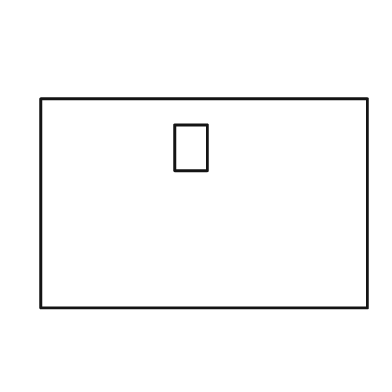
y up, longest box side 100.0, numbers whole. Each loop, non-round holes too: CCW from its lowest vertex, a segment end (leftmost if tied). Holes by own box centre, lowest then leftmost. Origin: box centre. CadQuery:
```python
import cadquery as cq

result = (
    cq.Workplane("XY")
    .moveTo(-50.0, -32.0)
    .lineTo(50.0, -32.0)
    .lineTo(50.0, 32.0)
    .lineTo(-50.0, 32.0)
    .close()
    .moveTo(-9.0, 10.0)
    .lineTo(1.0, 10.0)
    .lineTo(1.0, 24.0)
    .lineTo(-9.0, 24.0)
    .close()
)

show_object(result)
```